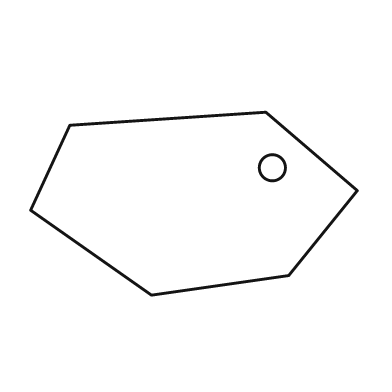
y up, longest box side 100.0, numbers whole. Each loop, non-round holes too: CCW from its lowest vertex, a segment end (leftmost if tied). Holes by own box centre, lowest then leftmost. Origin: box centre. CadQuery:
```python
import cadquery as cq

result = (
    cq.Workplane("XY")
    .moveTo(-13.0, -28.0)
    .lineTo(29.0, -22.0)
    .lineTo(50.0, 4.0)
    .lineTo(22.0, 28.0)
    .lineTo(-38.0, 24.0)
    .lineTo(-50.0, -2.0)
    .close()
    .moveTo(24.0, 11.0)
    .circle(4.0)
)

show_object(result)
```